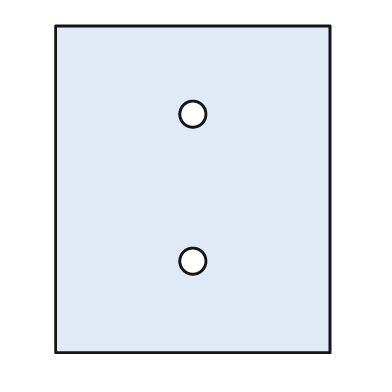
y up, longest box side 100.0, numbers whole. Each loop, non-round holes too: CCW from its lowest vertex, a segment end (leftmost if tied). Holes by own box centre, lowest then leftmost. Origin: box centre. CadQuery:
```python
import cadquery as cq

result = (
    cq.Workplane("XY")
    .moveTo(-42.0, -50.0)
    .lineTo(42.0, -50.0)
    .lineTo(42.0, 50.0)
    .lineTo(-42.0, 50.0)
    .close()
    .moveTo(0.0, -22.0)
    .circle(4.0)
    .moveTo(0.0, 23.0)
    .circle(4.0)
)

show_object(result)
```